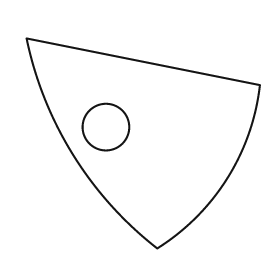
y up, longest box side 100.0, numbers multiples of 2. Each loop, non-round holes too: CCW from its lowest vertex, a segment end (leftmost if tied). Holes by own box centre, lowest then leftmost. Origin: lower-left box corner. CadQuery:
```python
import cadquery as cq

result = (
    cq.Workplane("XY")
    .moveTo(56.0, 0.0)
    .threePointArc((86.0, 30.0), (100.0, 70.0))
    .lineTo(0.0, 90.0)
    .threePointArc((20.0, 40.0), (56.0, 0.0))
    .close()
    .moveTo(34.0, 52.0)
    .circle(10.0)
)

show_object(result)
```